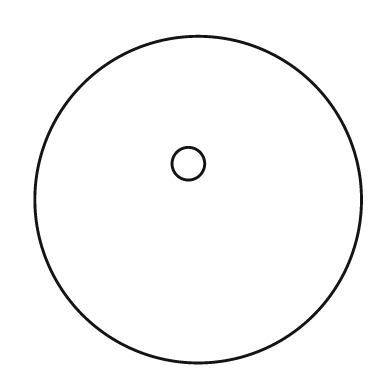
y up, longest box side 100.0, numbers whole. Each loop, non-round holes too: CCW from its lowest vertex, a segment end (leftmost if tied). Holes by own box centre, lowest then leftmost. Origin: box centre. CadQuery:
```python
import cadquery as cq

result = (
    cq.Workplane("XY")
    .moveTo(0.0, 0.0)
    .circle(50.0)
    .moveTo(-3.0, 11.0)
    .circle(5.0)
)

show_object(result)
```